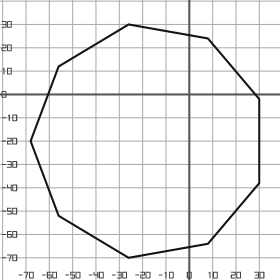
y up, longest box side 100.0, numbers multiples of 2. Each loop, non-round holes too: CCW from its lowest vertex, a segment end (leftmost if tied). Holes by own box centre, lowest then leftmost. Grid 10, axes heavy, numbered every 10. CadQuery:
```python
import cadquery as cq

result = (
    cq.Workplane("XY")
    .moveTo(-26.0, -70.0)
    .lineTo(8.0, -64.0)
    .lineTo(30.0, -38.0)
    .lineTo(30.0, -2.0)
    .lineTo(8.0, 24.0)
    .lineTo(-26.0, 30.0)
    .lineTo(-56.0, 12.0)
    .lineTo(-68.0, -20.0)
    .lineTo(-56.0, -52.0)
    .close()
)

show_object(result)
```